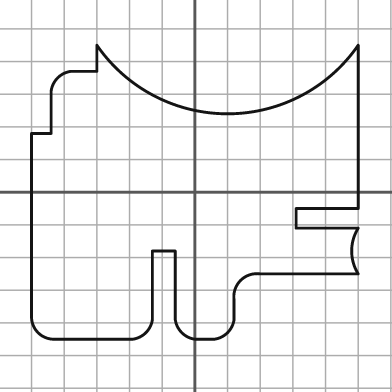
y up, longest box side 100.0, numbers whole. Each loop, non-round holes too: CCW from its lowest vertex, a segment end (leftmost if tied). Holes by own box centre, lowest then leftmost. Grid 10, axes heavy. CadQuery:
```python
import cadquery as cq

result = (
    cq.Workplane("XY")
    .moveTo(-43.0, -45.0)
    .lineTo(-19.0, -45.0)
    .threePointArc((-15.0, -43.0), (-13.0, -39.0))
    .lineTo(-13.0, -18.0)
    .lineTo(-6.0, -18.0)
    .lineTo(-6.0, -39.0)
    .threePointArc((-4.0, -43.0), (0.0, -45.0))
    .lineTo(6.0, -45.0)
    .threePointArc((10.0, -43.0), (12.0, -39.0))
    .lineTo(12.0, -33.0)
    .threePointArc((14.0, -27.0), (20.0, -25.0))
    .lineTo(50.0, -25.0)
    .threePointArc((48.0, -18.0), (50.0, -11.0))
    .lineTo(31.0, -11.0)
    .lineTo(31.0, -5.0)
    .lineTo(50.0, -5.0)
    .lineTo(50.0, 45.0)
    .threePointArc((10.0, 24.0), (-30.0, 45.0))
    .lineTo(-30.0, 37.0)
    .lineTo(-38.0, 37.0)
    .threePointArc((-42.0, 35.0), (-44.0, 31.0))
    .lineTo(-44.0, 18.0)
    .lineTo(-50.0, 18.0)
    .lineTo(-50.0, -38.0)
    .threePointArc((-48.0, -43.0), (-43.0, -45.0))
    .close()
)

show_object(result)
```